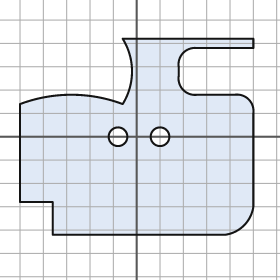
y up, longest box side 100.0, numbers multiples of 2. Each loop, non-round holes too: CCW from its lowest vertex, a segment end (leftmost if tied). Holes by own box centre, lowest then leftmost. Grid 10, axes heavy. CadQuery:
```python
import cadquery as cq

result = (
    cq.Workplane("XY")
    .moveTo(-36.0, -42.0)
    .lineTo(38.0, -42.0)
    .threePointArc((46.0, -38.0), (50.0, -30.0))
    .lineTo(50.0, 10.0)
    .threePointArc((48.0, 16.0), (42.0, 18.0))
    .lineTo(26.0, 18.0)
    .threePointArc((20.0, 20.0), (18.0, 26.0))
    .lineTo(18.0, 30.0)
    .threePointArc((20.0, 36.0), (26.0, 38.0))
    .lineTo(50.0, 38.0)
    .lineTo(50.0, 42.0)
    .lineTo(-6.0, 42.0)
    .threePointArc((-2.0, 28.0), (-6.0, 14.0))
    .threePointArc((-28.0, 18.0), (-50.0, 14.0))
    .lineTo(-50.0, -28.0)
    .lineTo(-36.0, -28.0)
    .close()
    .moveTo(-8.0, 0.0)
    .circle(4.0)
    .moveTo(10.0, 0.0)
    .circle(4.0)
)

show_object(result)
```